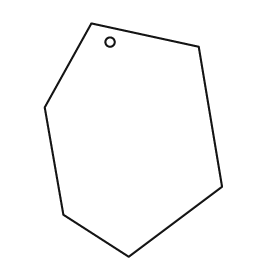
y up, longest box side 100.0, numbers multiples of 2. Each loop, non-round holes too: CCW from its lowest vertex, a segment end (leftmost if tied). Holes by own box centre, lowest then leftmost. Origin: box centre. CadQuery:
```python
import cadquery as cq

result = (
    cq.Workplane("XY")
    .moveTo(-2.0, -50.0)
    .lineTo(38.0, -20.0)
    .lineTo(28.0, 40.0)
    .lineTo(-18.0, 50.0)
    .lineTo(-38.0, 14.0)
    .lineTo(-30.0, -32.0)
    .close()
    .moveTo(-10.0, 42.0)
    .circle(2.0)
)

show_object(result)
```